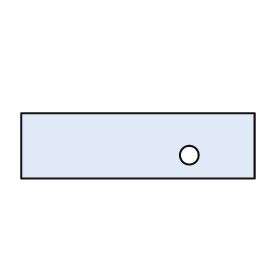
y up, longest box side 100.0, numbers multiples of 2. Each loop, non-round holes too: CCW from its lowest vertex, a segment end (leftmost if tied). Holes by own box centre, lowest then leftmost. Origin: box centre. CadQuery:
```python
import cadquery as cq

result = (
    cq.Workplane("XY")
    .moveTo(-50.0, -14.0)
    .lineTo(50.0, -14.0)
    .lineTo(50.0, 14.0)
    .lineTo(-50.0, 14.0)
    .close()
    .moveTo(22.0, -4.0)
    .circle(4.0)
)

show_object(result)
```